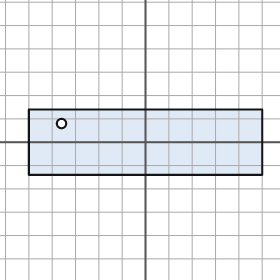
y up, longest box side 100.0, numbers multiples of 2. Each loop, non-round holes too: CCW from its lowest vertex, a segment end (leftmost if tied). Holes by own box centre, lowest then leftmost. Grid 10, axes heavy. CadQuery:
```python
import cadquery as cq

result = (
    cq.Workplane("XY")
    .moveTo(-50.0, -14.0)
    .lineTo(50.0, -14.0)
    .lineTo(50.0, 14.0)
    .lineTo(-50.0, 14.0)
    .close()
    .moveTo(-36.0, 8.0)
    .circle(2.0)
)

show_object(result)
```